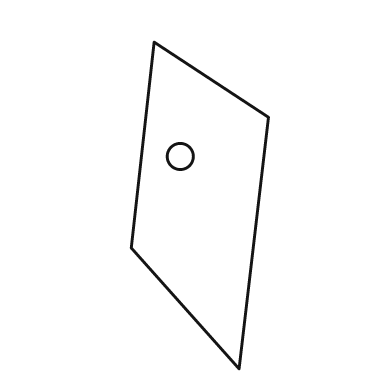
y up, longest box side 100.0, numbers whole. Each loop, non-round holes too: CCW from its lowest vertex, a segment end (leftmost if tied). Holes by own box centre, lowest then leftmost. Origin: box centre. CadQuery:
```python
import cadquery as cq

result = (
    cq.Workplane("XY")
    .moveTo(12.0, -50.0)
    .lineTo(21.0, 27.0)
    .lineTo(-14.0, 50.0)
    .lineTo(-21.0, -13.0)
    .close()
    .moveTo(-6.0, 15.0)
    .circle(4.0)
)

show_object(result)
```